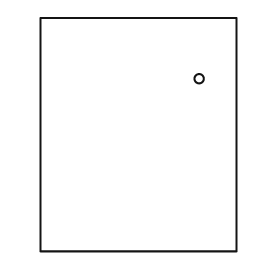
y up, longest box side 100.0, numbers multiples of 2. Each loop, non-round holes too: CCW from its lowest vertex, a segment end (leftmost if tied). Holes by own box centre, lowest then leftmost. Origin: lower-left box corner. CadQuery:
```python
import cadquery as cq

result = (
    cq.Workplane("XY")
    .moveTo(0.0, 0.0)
    .lineTo(84.0, 0.0)
    .lineTo(84.0, 100.0)
    .lineTo(0.0, 100.0)
    .close()
    .moveTo(68.0, 74.0)
    .circle(2.0)
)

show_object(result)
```